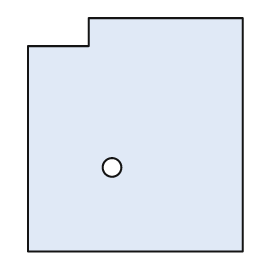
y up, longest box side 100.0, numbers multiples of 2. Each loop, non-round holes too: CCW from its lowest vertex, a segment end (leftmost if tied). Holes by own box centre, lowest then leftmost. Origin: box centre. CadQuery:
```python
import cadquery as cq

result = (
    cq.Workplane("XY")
    .moveTo(-46.0, -50.0)
    .lineTo(46.0, -50.0)
    .lineTo(46.0, 50.0)
    .lineTo(-20.0, 50.0)
    .lineTo(-20.0, 38.0)
    .lineTo(-46.0, 38.0)
    .close()
    .moveTo(-10.0, -14.0)
    .circle(4.0)
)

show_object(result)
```